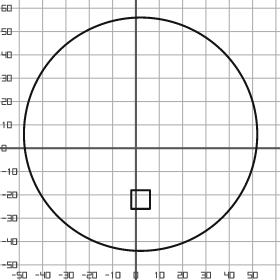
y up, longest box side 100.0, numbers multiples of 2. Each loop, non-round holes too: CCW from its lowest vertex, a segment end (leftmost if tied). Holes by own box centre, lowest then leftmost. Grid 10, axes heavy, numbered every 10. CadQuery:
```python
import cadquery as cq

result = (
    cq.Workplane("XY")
    .moveTo(2.0, 6.0)
    .circle(50.0)
    .moveTo(-2.0, -26.0)
    .lineTo(6.0, -26.0)
    .lineTo(6.0, -18.0)
    .lineTo(-2.0, -18.0)
    .close()
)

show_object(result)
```